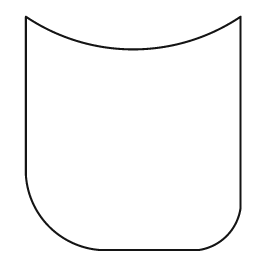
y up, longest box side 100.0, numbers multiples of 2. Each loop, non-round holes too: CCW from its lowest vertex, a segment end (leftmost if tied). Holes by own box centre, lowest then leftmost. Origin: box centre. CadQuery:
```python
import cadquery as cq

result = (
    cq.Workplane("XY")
    .moveTo(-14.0, -50.0)
    .lineTo(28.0, -50.0)
    .threePointArc((40.0, -44.0), (46.0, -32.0))
    .lineTo(46.0, 50.0)
    .threePointArc((0.0, 36.0), (-46.0, 50.0))
    .lineTo(-46.0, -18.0)
    .threePointArc((-36.0, -40.0), (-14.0, -50.0))
    .close()
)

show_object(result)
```